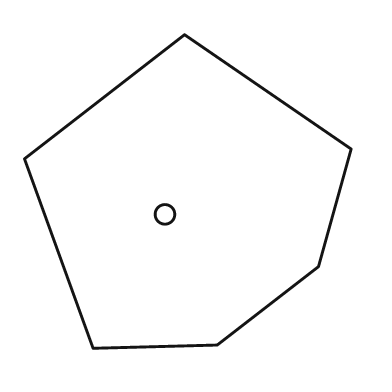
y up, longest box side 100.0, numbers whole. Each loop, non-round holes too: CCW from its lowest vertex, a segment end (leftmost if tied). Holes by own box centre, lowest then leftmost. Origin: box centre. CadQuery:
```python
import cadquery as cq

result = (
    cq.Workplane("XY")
    .moveTo(-29.0, -48.0)
    .lineTo(9.0, -47.0)
    .lineTo(40.0, -23.0)
    .lineTo(50.0, 13.0)
    .lineTo(-1.0, 48.0)
    .lineTo(-50.0, 10.0)
    .close()
    .moveTo(-7.0, -7.0)
    .circle(3.0)
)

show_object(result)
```